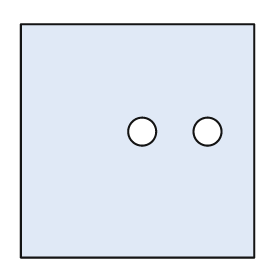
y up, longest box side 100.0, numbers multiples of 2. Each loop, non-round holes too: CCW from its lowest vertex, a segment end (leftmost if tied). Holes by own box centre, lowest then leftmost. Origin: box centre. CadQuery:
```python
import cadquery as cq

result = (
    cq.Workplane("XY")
    .moveTo(-50.0, -50.0)
    .lineTo(50.0, -50.0)
    .lineTo(50.0, 50.0)
    .lineTo(-50.0, 50.0)
    .close()
    .moveTo(2.0, 4.0)
    .circle(6.0)
    .moveTo(30.0, 4.0)
    .circle(6.0)
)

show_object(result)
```